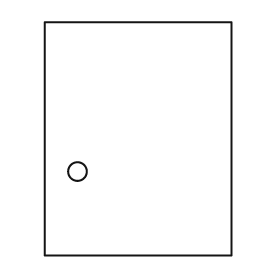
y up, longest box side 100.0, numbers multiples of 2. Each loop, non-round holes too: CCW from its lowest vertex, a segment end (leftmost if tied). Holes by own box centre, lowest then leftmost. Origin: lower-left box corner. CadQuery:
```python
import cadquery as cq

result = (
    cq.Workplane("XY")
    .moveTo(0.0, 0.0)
    .lineTo(80.0, 0.0)
    .lineTo(80.0, 100.0)
    .lineTo(0.0, 100.0)
    .close()
    .moveTo(14.0, 36.0)
    .circle(4.0)
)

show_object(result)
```